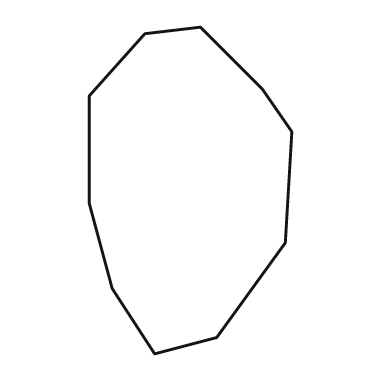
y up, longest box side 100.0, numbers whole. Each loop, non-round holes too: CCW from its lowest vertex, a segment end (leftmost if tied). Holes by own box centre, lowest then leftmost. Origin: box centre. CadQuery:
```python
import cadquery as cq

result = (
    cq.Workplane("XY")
    .moveTo(-11.0, -50.0)
    .lineTo(8.0, -45.0)
    .lineTo(29.0, -16.0)
    .lineTo(31.0, 18.0)
    .lineTo(22.0, 31.0)
    .lineTo(3.0, 50.0)
    .lineTo(-14.0, 48.0)
    .lineTo(-31.0, 29.0)
    .lineTo(-31.0, -4.0)
    .lineTo(-24.0, -30.0)
    .close()
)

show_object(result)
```